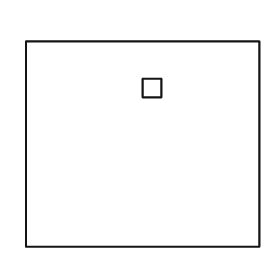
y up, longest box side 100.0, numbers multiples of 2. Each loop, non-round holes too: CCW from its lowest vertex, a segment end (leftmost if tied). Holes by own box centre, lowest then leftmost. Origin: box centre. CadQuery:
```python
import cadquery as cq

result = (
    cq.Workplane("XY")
    .moveTo(-50.0, -44.0)
    .lineTo(50.0, -44.0)
    .lineTo(50.0, 44.0)
    .lineTo(-50.0, 44.0)
    .close()
    .moveTo(0.0, 20.0)
    .lineTo(8.0, 20.0)
    .lineTo(8.0, 28.0)
    .lineTo(0.0, 28.0)
    .close()
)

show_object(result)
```